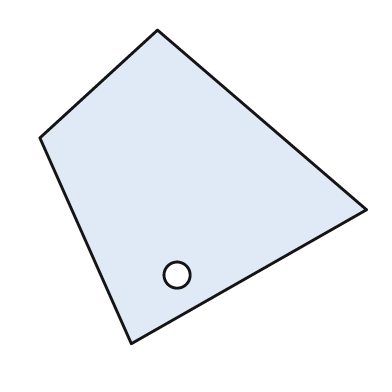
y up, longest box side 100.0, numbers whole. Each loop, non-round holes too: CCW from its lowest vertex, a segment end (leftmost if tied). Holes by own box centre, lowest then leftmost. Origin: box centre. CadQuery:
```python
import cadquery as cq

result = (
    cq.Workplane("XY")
    .moveTo(-22.0, -48.0)
    .lineTo(50.0, -7.0)
    .lineTo(-14.0, 48.0)
    .lineTo(-50.0, 15.0)
    .close()
    .moveTo(-8.0, -27.0)
    .circle(4.0)
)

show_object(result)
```